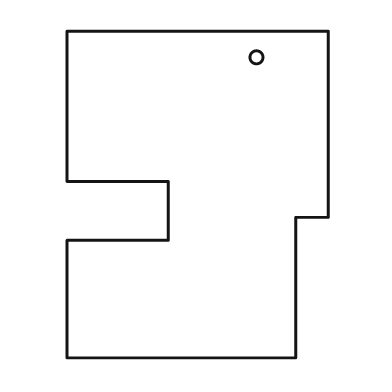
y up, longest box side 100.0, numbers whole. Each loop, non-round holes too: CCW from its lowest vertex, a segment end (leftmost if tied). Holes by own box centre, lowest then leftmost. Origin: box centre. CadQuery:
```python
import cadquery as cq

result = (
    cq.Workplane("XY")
    .moveTo(-40.0, -50.0)
    .lineTo(30.0, -50.0)
    .lineTo(30.0, -7.0)
    .lineTo(40.0, -7.0)
    .lineTo(40.0, 50.0)
    .lineTo(-40.0, 50.0)
    .lineTo(-40.0, 4.0)
    .lineTo(-9.0, 4.0)
    .lineTo(-9.0, -14.0)
    .lineTo(-40.0, -14.0)
    .close()
    .moveTo(18.0, 42.0)
    .circle(2.0)
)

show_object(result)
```